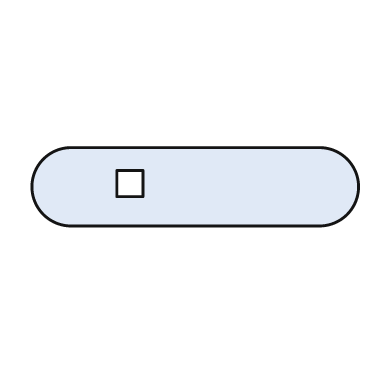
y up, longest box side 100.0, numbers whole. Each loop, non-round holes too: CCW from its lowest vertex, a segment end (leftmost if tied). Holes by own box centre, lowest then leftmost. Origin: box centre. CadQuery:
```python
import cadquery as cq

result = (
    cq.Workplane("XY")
    .moveTo(-38.0, -12.0)
    .lineTo(38.0, -12.0)
    .threePointArc((50.0, 0.0), (38.0, 12.0))
    .lineTo(-38.0, 12.0)
    .threePointArc((-50.0, 0.0), (-38.0, -12.0))
    .close()
    .moveTo(-24.0, -3.0)
    .lineTo(-16.0, -3.0)
    .lineTo(-16.0, 5.0)
    .lineTo(-24.0, 5.0)
    .close()
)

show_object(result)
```